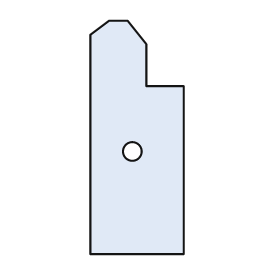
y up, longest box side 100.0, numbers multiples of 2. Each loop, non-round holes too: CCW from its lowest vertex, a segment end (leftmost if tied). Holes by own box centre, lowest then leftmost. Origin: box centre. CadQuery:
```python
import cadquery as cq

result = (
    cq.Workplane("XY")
    .moveTo(-20.0, -50.0)
    .lineTo(20.0, -50.0)
    .lineTo(20.0, 22.0)
    .lineTo(4.0, 22.0)
    .lineTo(4.0, 40.0)
    .lineTo(-4.0, 50.0)
    .lineTo(-12.0, 50.0)
    .lineTo(-20.0, 44.0)
    .close()
    .moveTo(-2.0, -6.0)
    .circle(4.0)
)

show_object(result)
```